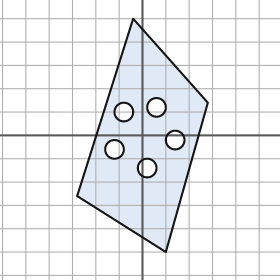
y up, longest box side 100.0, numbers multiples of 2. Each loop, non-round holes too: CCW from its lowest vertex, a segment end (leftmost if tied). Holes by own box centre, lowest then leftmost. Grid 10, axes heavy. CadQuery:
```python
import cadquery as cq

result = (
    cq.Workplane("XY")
    .moveTo(10.0, -50.0)
    .lineTo(28.0, 14.0)
    .lineTo(-4.0, 50.0)
    .lineTo(-28.0, -26.0)
    .close()
    .moveTo(2.0, -14.0)
    .circle(4.0)
    .moveTo(-12.0, -6.0)
    .circle(4.0)
    .moveTo(14.0, -2.0)
    .circle(4.0)
    .moveTo(-8.0, 10.0)
    .circle(4.0)
    .moveTo(6.0, 12.0)
    .circle(4.0)
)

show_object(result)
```